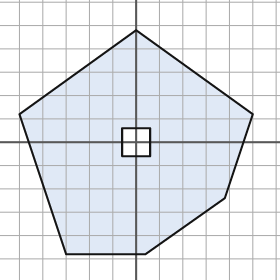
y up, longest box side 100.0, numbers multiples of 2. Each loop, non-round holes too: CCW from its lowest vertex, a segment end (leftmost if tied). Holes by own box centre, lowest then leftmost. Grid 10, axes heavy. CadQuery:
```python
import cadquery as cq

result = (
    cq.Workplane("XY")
    .moveTo(-30.0, -48.0)
    .lineTo(4.0, -48.0)
    .lineTo(38.0, -24.0)
    .lineTo(50.0, 12.0)
    .lineTo(0.0, 48.0)
    .lineTo(-50.0, 12.0)
    .close()
    .moveTo(-6.0, -6.0)
    .lineTo(6.0, -6.0)
    .lineTo(6.0, 6.0)
    .lineTo(-6.0, 6.0)
    .close()
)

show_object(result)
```